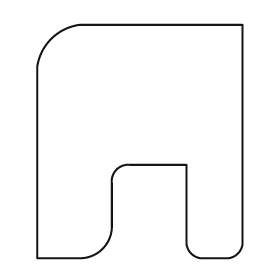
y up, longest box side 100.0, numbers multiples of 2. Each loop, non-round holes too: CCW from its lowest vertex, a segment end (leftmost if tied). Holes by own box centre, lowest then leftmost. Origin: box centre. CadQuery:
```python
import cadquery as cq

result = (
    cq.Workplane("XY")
    .moveTo(-44.0, -50.0)
    .lineTo(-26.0, -50.0)
    .threePointArc((-16.0, -46.0), (-12.0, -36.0))
    .lineTo(-12.0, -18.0)
    .threePointArc((-10.0, -12.0), (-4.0, -10.0))
    .lineTo(20.0, -10.0)
    .lineTo(20.0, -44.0)
    .threePointArc((22.0, -48.0), (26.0, -50.0))
    .lineTo(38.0, -50.0)
    .threePointArc((42.0, -48.0), (44.0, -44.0))
    .lineTo(44.0, 50.0)
    .lineTo(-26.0, 50.0)
    .threePointArc((-38.0, 44.0), (-44.0, 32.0))
    .close()
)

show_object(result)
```